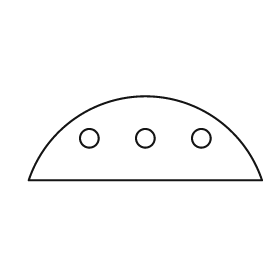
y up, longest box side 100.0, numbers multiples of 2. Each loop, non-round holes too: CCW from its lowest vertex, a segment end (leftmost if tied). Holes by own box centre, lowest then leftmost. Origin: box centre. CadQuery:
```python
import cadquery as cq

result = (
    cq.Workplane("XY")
    .moveTo(-50.0, -18.0)
    .lineTo(50.0, -18.0)
    .threePointArc((0.0, 18.0), (-50.0, -18.0))
    .close()
    .moveTo(-24.0, 0.0)
    .circle(4.0)
    .moveTo(0.0, 0.0)
    .circle(4.0)
    .moveTo(24.0, 0.0)
    .circle(4.0)
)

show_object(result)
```